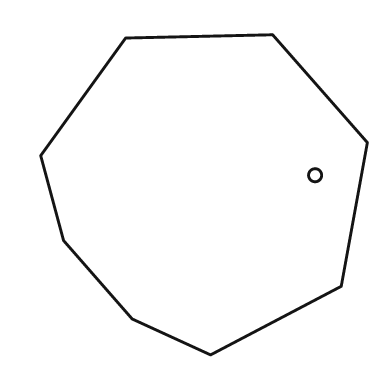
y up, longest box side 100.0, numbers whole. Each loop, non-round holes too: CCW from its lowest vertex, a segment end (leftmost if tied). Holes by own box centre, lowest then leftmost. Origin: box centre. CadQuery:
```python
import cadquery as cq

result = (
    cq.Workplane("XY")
    .moveTo(2.0, -49.0)
    .lineTo(42.0, -28.0)
    .lineTo(50.0, 16.0)
    .lineTo(21.0, 49.0)
    .lineTo(-24.0, 48.0)
    .lineTo(-50.0, 12.0)
    .lineTo(-43.0, -14.0)
    .lineTo(-22.0, -38.0)
    .close()
    .moveTo(34.0, 6.0)
    .circle(2.0)
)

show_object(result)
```